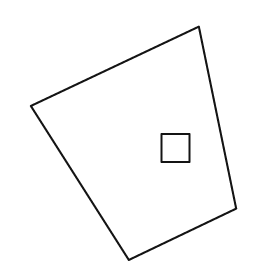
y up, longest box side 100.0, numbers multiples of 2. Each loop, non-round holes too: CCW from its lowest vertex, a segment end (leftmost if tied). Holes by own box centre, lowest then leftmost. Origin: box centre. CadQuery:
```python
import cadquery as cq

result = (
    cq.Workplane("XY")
    .moveTo(-2.0, -50.0)
    .lineTo(44.0, -28.0)
    .lineTo(28.0, 50.0)
    .lineTo(-44.0, 16.0)
    .close()
    .moveTo(12.0, -8.0)
    .lineTo(24.0, -8.0)
    .lineTo(24.0, 4.0)
    .lineTo(12.0, 4.0)
    .close()
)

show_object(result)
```